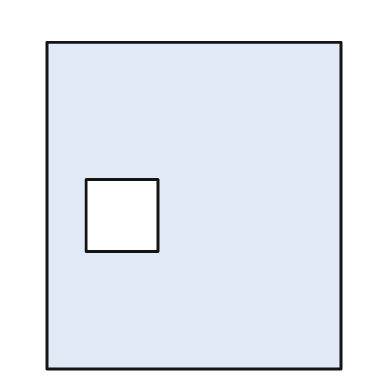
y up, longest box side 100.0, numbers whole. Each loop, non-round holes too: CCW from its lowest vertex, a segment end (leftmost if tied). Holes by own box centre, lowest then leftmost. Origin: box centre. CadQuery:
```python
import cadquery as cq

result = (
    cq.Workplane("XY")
    .moveTo(-45.0, -50.0)
    .lineTo(45.0, -50.0)
    .lineTo(45.0, 50.0)
    .lineTo(-45.0, 50.0)
    .close()
    .moveTo(-33.0, -14.0)
    .lineTo(-11.0, -14.0)
    .lineTo(-11.0, 8.0)
    .lineTo(-33.0, 8.0)
    .close()
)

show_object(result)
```